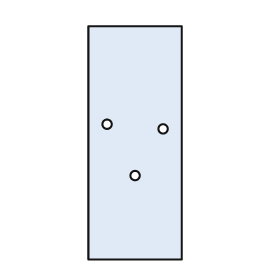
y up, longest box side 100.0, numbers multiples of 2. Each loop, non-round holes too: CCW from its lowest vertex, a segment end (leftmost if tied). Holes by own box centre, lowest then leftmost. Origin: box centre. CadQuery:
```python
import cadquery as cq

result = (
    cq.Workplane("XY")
    .moveTo(-20.0, -50.0)
    .lineTo(20.0, -50.0)
    .lineTo(20.0, 50.0)
    .lineTo(-20.0, 50.0)
    .close()
    .moveTo(0.0, -14.0)
    .circle(2.0)
    .moveTo(12.0, 6.0)
    .circle(2.0)
    .moveTo(-12.0, 8.0)
    .circle(2.0)
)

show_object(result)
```